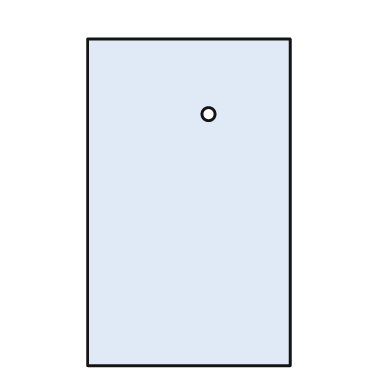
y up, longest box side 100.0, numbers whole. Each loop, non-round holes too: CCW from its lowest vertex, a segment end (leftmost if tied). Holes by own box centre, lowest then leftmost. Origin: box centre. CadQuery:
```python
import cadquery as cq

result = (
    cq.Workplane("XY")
    .moveTo(-31.0, -50.0)
    .lineTo(31.0, -50.0)
    .lineTo(31.0, 50.0)
    .lineTo(-31.0, 50.0)
    .close()
    .moveTo(6.0, 27.0)
    .circle(2.0)
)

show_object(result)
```